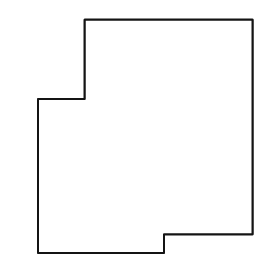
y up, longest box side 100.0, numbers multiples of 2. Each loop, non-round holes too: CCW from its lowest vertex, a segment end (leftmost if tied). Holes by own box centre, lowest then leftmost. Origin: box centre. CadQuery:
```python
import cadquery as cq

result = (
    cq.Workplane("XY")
    .moveTo(-46.0, -50.0)
    .lineTo(8.0, -50.0)
    .lineTo(8.0, -42.0)
    .lineTo(46.0, -42.0)
    .lineTo(46.0, 50.0)
    .lineTo(-26.0, 50.0)
    .lineTo(-26.0, 16.0)
    .lineTo(-46.0, 16.0)
    .close()
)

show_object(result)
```